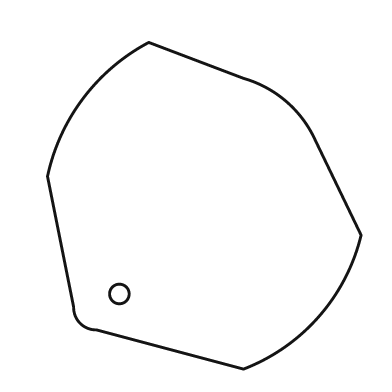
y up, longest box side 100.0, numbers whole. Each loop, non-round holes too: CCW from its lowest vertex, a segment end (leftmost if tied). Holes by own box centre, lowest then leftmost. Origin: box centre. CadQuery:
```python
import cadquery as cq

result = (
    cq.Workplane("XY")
    .moveTo(12.0, -50.0)
    .threePointArc((35.0, -34.0), (48.0, -9.0))
    .lineTo(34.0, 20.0)
    .threePointArc((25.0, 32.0), (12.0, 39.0))
    .lineTo(-17.0, 50.0)
    .threePointArc((-37.0, 33.0), (-48.0, 9.0))
    .lineTo(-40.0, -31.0)
    .threePointArc((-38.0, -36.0), (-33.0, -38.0))
    .close()
    .moveTo(-26.0, -27.0)
    .circle(3.0)
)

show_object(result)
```